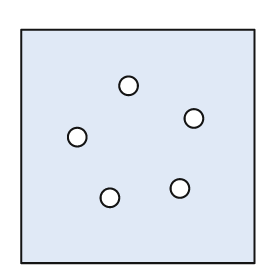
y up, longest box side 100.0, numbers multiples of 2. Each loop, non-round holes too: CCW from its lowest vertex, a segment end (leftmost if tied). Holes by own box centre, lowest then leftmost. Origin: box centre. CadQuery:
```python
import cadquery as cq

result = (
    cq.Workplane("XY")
    .moveTo(-50.0, -50.0)
    .lineTo(50.0, -50.0)
    .lineTo(50.0, 50.0)
    .lineTo(-50.0, 50.0)
    .close()
    .moveTo(-12.0, -22.0)
    .circle(4.0)
    .moveTo(18.0, -18.0)
    .circle(4.0)
    .moveTo(-26.0, 4.0)
    .circle(4.0)
    .moveTo(24.0, 12.0)
    .circle(4.0)
    .moveTo(-4.0, 26.0)
    .circle(4.0)
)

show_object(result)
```